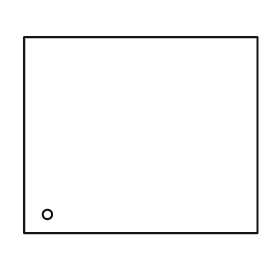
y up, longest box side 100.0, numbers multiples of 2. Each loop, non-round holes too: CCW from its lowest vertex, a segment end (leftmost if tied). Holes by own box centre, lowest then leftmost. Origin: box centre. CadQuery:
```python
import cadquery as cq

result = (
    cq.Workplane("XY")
    .moveTo(-50.0, -42.0)
    .lineTo(50.0, -42.0)
    .lineTo(50.0, 42.0)
    .lineTo(-50.0, 42.0)
    .close()
    .moveTo(-40.0, -34.0)
    .circle(2.0)
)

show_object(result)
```